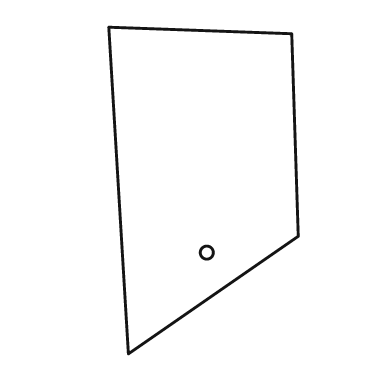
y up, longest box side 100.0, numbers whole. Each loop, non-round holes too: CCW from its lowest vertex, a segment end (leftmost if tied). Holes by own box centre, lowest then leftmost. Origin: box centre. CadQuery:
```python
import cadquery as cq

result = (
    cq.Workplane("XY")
    .moveTo(-23.0, -50.0)
    .lineTo(29.0, -14.0)
    .lineTo(27.0, 48.0)
    .lineTo(-29.0, 50.0)
    .close()
    .moveTo(1.0, -19.0)
    .circle(2.0)
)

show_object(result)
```